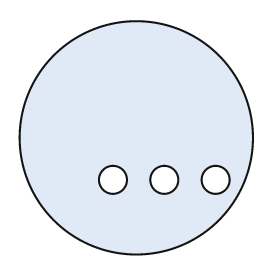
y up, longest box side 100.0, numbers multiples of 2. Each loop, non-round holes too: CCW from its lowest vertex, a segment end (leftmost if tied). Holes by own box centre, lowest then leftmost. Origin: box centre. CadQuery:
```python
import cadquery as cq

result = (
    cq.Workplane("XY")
    .moveTo(0.0, 0.0)
    .circle(50.0)
    .moveTo(-10.0, -18.0)
    .circle(6.0)
    .moveTo(12.0, -18.0)
    .circle(6.0)
    .moveTo(34.0, -18.0)
    .circle(6.0)
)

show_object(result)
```